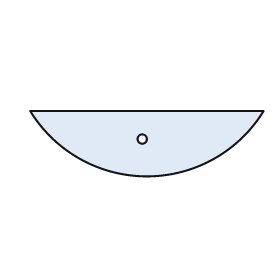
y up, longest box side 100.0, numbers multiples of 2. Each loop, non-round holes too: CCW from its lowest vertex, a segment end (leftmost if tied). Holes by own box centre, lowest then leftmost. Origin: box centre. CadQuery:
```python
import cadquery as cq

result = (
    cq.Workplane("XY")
    .moveTo(-50.0, 14.0)
    .threePointArc((0.0, -14.0), (50.0, 14.0))
    .close()
    .moveTo(-2.0, 2.0)
    .circle(2.0)
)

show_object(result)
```